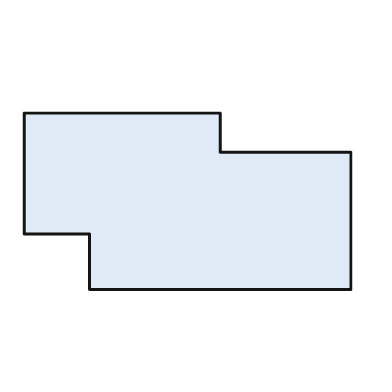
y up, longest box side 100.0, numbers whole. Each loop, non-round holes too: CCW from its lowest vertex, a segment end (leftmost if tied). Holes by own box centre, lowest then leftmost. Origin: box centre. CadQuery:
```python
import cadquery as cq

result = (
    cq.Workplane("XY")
    .moveTo(-30.0, -27.0)
    .lineTo(50.0, -27.0)
    .lineTo(50.0, 15.0)
    .lineTo(10.0, 15.0)
    .lineTo(10.0, 27.0)
    .lineTo(-50.0, 27.0)
    .lineTo(-50.0, -10.0)
    .lineTo(-30.0, -10.0)
    .close()
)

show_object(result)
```